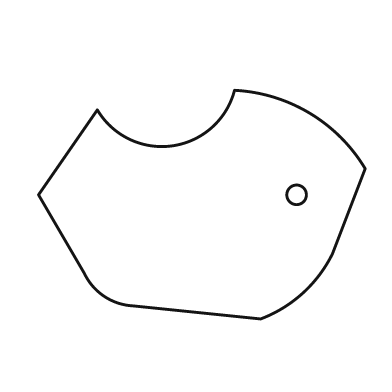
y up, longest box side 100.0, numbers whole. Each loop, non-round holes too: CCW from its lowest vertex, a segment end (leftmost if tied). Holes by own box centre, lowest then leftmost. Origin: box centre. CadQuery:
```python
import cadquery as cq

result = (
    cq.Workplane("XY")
    .moveTo(18.0, -35.0)
    .threePointArc((31.0, -27.0), (40.0, -15.0))
    .lineTo(50.0, 11.0)
    .threePointArc((33.0, 28.0), (10.0, 35.0))
    .threePointArc((-9.0, 18.0), (-32.0, 29.0))
    .lineTo(-50.0, 3.0)
    .lineTo(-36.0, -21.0)
    .threePointArc((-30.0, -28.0), (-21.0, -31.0))
    .close()
    .moveTo(29.0, 3.0)
    .circle(3.0)
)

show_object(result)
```